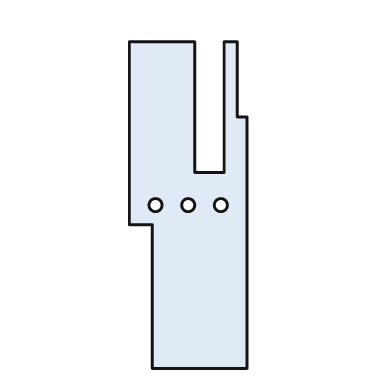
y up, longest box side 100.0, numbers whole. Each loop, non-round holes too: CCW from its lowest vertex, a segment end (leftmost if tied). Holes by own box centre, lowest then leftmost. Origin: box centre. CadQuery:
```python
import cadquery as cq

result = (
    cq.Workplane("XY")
    .moveTo(-11.0, -50.0)
    .lineTo(18.0, -50.0)
    .lineTo(18.0, 27.0)
    .lineTo(15.0, 27.0)
    .lineTo(15.0, 50.0)
    .lineTo(11.0, 50.0)
    .lineTo(11.0, 10.0)
    .lineTo(2.0, 10.0)
    .lineTo(2.0, 50.0)
    .lineTo(-18.0, 50.0)
    .lineTo(-18.0, -6.0)
    .lineTo(-11.0, -6.0)
    .close()
    .moveTo(-10.0, 0.0)
    .circle(2.0)
    .moveTo(0.0, 0.0)
    .circle(2.0)
    .moveTo(10.0, 0.0)
    .circle(2.0)
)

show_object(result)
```